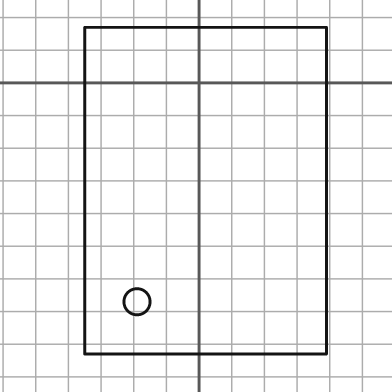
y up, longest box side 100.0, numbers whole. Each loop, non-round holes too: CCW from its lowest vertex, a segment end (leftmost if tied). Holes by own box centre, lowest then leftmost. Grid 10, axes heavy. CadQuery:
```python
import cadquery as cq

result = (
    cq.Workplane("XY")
    .moveTo(-35.0, -83.0)
    .lineTo(39.0, -83.0)
    .lineTo(39.0, 17.0)
    .lineTo(-35.0, 17.0)
    .close()
    .moveTo(-19.0, -67.0)
    .circle(4.0)
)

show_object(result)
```